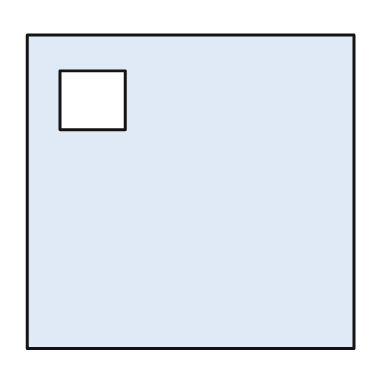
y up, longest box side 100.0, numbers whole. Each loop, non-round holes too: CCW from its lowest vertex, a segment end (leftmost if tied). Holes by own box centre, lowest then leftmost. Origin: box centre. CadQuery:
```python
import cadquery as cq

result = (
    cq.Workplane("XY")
    .moveTo(-50.0, -48.0)
    .lineTo(50.0, -48.0)
    .lineTo(50.0, 48.0)
    .lineTo(-50.0, 48.0)
    .close()
    .moveTo(-40.0, 19.0)
    .lineTo(-20.0, 19.0)
    .lineTo(-20.0, 37.0)
    .lineTo(-40.0, 37.0)
    .close()
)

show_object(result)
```